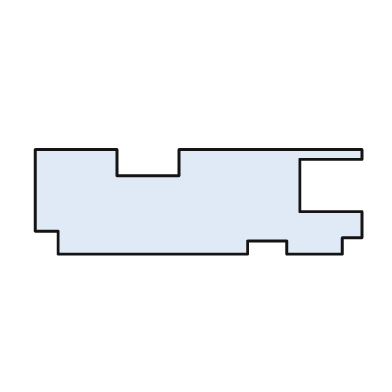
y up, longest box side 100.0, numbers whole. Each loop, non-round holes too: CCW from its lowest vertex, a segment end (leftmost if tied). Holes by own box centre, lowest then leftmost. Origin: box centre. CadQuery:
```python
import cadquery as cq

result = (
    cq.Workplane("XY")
    .moveTo(-43.0, -16.0)
    .lineTo(15.0, -16.0)
    .lineTo(15.0, -12.0)
    .lineTo(27.0, -12.0)
    .lineTo(27.0, -16.0)
    .lineTo(44.0, -16.0)
    .lineTo(44.0, -11.0)
    .lineTo(50.0, -11.0)
    .lineTo(50.0, -3.0)
    .lineTo(31.0, -3.0)
    .lineTo(31.0, 13.0)
    .lineTo(50.0, 13.0)
    .lineTo(50.0, 16.0)
    .lineTo(-6.0, 16.0)
    .lineTo(-6.0, 8.0)
    .lineTo(-25.0, 8.0)
    .lineTo(-25.0, 16.0)
    .lineTo(-50.0, 16.0)
    .lineTo(-50.0, -9.0)
    .lineTo(-43.0, -9.0)
    .close()
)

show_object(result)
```